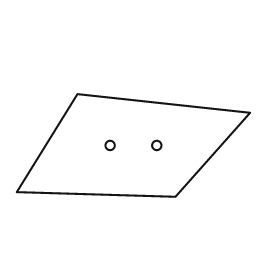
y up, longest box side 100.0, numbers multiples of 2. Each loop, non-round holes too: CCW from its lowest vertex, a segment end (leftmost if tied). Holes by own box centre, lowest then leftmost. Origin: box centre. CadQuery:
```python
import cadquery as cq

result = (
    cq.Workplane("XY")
    .moveTo(18.0, -22.0)
    .lineTo(50.0, 14.0)
    .lineTo(-24.0, 22.0)
    .lineTo(-50.0, -20.0)
    .close()
    .moveTo(-10.0, 0.0)
    .circle(2.0)
    .moveTo(10.0, 0.0)
    .circle(2.0)
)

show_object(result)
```